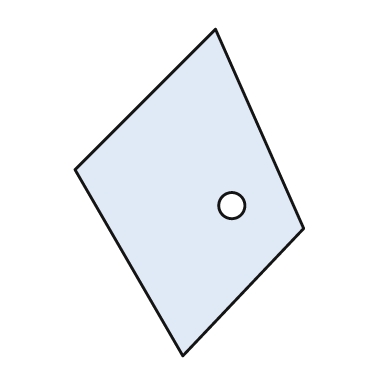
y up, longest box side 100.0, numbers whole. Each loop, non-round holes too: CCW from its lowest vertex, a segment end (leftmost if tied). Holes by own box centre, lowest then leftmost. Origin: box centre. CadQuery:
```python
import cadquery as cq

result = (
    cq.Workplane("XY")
    .moveTo(-2.0, -50.0)
    .lineTo(35.0, -11.0)
    .lineTo(8.0, 50.0)
    .lineTo(-35.0, 7.0)
    .close()
    .moveTo(13.0, -4.0)
    .circle(4.0)
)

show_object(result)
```